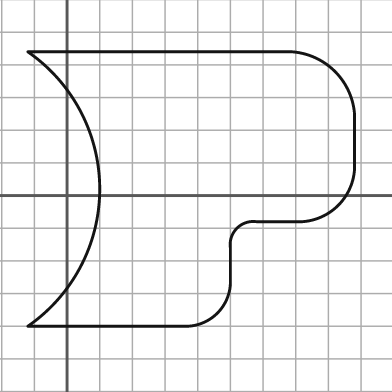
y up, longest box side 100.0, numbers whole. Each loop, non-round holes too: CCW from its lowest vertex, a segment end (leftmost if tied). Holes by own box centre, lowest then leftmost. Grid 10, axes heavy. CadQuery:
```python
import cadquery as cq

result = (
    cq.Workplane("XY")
    .moveTo(-12.0, -40.0)
    .lineTo(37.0, -40.0)
    .threePointArc((46.0, -36.0), (50.0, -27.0))
    .lineTo(50.0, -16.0)
    .threePointArc((52.0, -10.0), (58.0, -8.0))
    .lineTo(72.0, -8.0)
    .threePointArc((83.0, -3.0), (88.0, 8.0))
    .lineTo(88.0, 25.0)
    .threePointArc((82.0, 38.0), (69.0, 44.0))
    .lineTo(-12.0, 44.0)
    .threePointArc((10.0, 2.0), (-12.0, -40.0))
    .close()
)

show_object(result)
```